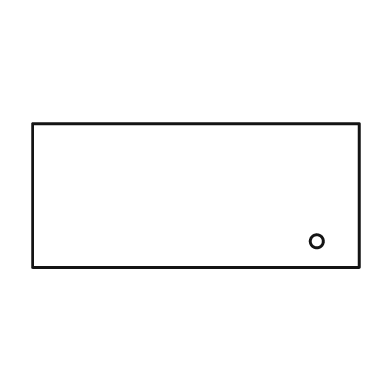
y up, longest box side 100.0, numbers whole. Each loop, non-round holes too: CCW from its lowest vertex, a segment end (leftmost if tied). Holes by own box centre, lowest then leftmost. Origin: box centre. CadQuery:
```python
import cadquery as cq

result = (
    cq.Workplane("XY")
    .moveTo(-50.0, -22.0)
    .lineTo(50.0, -22.0)
    .lineTo(50.0, 22.0)
    .lineTo(-50.0, 22.0)
    .close()
    .moveTo(37.0, -14.0)
    .circle(2.0)
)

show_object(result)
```